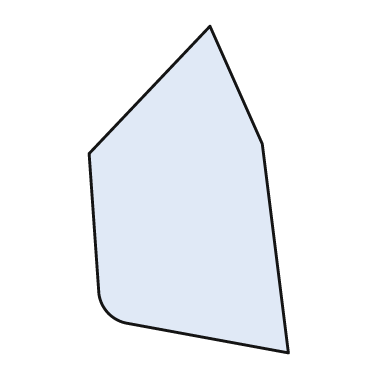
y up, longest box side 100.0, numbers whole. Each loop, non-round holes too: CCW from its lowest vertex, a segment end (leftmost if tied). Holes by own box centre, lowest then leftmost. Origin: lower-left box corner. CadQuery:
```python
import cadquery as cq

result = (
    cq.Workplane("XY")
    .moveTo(61.0, 0.0)
    .lineTo(53.0, 64.0)
    .lineTo(37.0, 100.0)
    .lineTo(0.0, 61.0)
    .lineTo(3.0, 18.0)
    .threePointArc((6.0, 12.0), (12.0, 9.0))
    .close()
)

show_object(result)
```